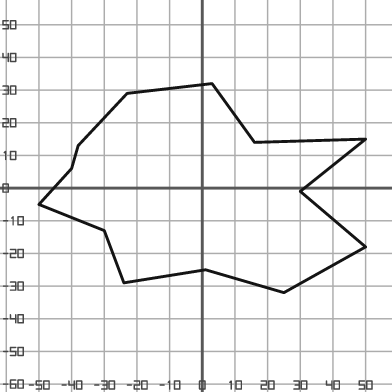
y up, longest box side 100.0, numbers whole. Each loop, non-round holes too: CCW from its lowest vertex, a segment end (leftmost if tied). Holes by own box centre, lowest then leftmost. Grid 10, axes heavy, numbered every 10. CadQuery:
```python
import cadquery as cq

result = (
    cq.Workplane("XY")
    .moveTo(25.0, -32.0)
    .lineTo(50.0, -18.0)
    .lineTo(30.0, -1.0)
    .lineTo(50.0, 15.0)
    .lineTo(16.0, 14.0)
    .lineTo(3.0, 32.0)
    .lineTo(-23.0, 29.0)
    .lineTo(-38.0, 13.0)
    .lineTo(-40.0, 6.0)
    .lineTo(-50.0, -5.0)
    .lineTo(-30.0, -13.0)
    .lineTo(-24.0, -29.0)
    .lineTo(1.0, -25.0)
    .close()
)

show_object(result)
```